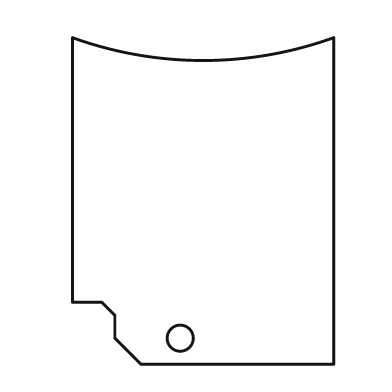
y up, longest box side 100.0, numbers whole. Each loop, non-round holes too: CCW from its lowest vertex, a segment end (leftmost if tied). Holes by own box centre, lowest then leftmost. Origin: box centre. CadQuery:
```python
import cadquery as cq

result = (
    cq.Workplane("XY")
    .moveTo(-19.0, -50.0)
    .lineTo(40.0, -50.0)
    .lineTo(40.0, 50.0)
    .threePointArc((0.0, 43.0), (-40.0, 50.0))
    .lineTo(-40.0, -31.0)
    .lineTo(-31.0, -31.0)
    .lineTo(-27.0, -35.0)
    .lineTo(-27.0, -42.0)
    .close()
    .moveTo(-7.0, -42.0)
    .circle(4.0)
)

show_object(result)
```